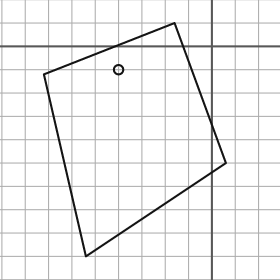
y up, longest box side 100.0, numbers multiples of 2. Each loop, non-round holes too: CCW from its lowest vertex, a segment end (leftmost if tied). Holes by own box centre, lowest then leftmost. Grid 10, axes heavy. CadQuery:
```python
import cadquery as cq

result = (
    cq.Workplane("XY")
    .moveTo(-54.0, -90.0)
    .lineTo(6.0, -50.0)
    .lineTo(-16.0, 10.0)
    .lineTo(-72.0, -12.0)
    .close()
    .moveTo(-40.0, -10.0)
    .circle(2.0)
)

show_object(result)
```